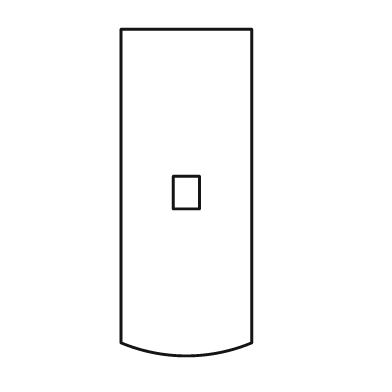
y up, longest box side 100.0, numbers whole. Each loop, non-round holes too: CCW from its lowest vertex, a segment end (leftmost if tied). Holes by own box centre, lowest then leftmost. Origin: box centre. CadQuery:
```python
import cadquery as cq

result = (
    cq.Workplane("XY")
    .moveTo(-20.0, -46.0)
    .threePointArc((0.0, -50.0), (20.0, -46.0))
    .lineTo(20.0, 50.0)
    .lineTo(-20.0, 50.0)
    .close()
    .moveTo(-4.0, -5.0)
    .lineTo(4.0, -5.0)
    .lineTo(4.0, 5.0)
    .lineTo(-4.0, 5.0)
    .close()
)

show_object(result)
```